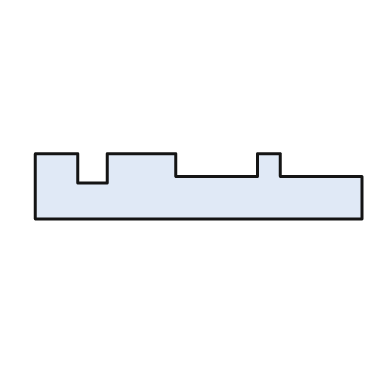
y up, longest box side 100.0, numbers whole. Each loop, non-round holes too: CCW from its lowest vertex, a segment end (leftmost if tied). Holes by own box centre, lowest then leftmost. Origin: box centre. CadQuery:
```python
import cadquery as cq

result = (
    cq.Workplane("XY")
    .moveTo(-50.0, -10.0)
    .lineTo(50.0, -10.0)
    .lineTo(50.0, 3.0)
    .lineTo(25.0, 3.0)
    .lineTo(25.0, 10.0)
    .lineTo(18.0, 10.0)
    .lineTo(18.0, 3.0)
    .lineTo(-7.0, 3.0)
    .lineTo(-7.0, 10.0)
    .lineTo(-28.0, 10.0)
    .lineTo(-28.0, 1.0)
    .lineTo(-37.0, 1.0)
    .lineTo(-37.0, 10.0)
    .lineTo(-50.0, 10.0)
    .close()
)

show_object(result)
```